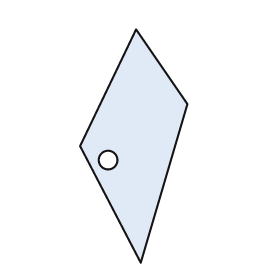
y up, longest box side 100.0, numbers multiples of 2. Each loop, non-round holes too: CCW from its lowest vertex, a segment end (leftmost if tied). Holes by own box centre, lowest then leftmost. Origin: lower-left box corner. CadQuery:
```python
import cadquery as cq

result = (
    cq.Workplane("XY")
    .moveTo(26.0, 0.0)
    .lineTo(46.0, 68.0)
    .lineTo(24.0, 100.0)
    .lineTo(0.0, 50.0)
    .close()
    .moveTo(12.0, 44.0)
    .circle(4.0)
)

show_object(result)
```